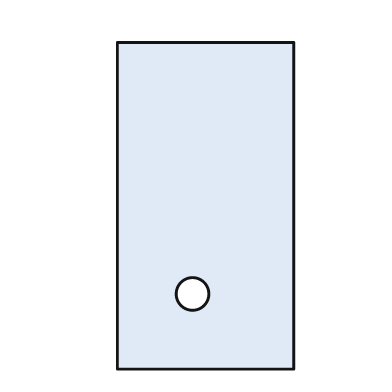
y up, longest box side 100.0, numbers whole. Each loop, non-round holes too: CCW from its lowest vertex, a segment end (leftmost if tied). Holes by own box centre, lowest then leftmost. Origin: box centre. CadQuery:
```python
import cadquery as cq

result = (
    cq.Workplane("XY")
    .moveTo(-27.0, -50.0)
    .lineTo(27.0, -50.0)
    .lineTo(27.0, 50.0)
    .lineTo(-27.0, 50.0)
    .close()
    .moveTo(-4.0, -27.0)
    .circle(5.0)
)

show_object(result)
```